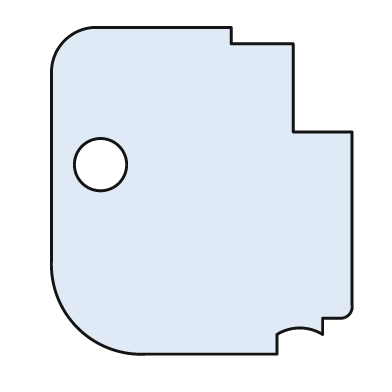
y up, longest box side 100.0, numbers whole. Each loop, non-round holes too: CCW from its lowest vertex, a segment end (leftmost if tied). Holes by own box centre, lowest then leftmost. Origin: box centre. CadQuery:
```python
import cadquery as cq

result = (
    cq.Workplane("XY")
    .moveTo(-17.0, -50.0)
    .lineTo(23.0, -50.0)
    .lineTo(23.0, -44.0)
    .threePointArc((30.0, -42.0), (37.0, -44.0))
    .lineTo(37.0, -39.0)
    .lineTo(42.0, -39.0)
    .threePointArc((45.0, -38.0), (46.0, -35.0))
    .lineTo(46.0, 18.0)
    .lineTo(28.0, 18.0)
    .lineTo(28.0, 45.0)
    .lineTo(9.0, 45.0)
    .lineTo(9.0, 50.0)
    .lineTo(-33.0, 50.0)
    .threePointArc((-42.0, 46.0), (-46.0, 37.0))
    .lineTo(-46.0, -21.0)
    .threePointArc((-38.0, -42.0), (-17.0, -50.0))
    .close()
    .moveTo(-31.0, 8.0)
    .circle(8.0)
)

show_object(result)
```